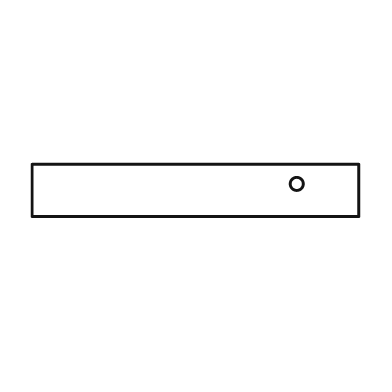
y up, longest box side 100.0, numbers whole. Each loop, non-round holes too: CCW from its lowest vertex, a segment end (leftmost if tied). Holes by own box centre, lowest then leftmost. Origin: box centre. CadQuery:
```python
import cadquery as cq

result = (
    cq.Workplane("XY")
    .moveTo(-50.0, -8.0)
    .lineTo(50.0, -8.0)
    .lineTo(50.0, 8.0)
    .lineTo(-50.0, 8.0)
    .close()
    .moveTo(31.0, 2.0)
    .circle(2.0)
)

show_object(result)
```